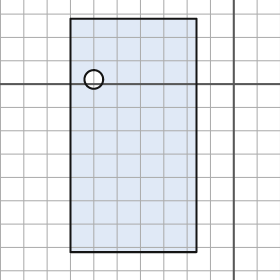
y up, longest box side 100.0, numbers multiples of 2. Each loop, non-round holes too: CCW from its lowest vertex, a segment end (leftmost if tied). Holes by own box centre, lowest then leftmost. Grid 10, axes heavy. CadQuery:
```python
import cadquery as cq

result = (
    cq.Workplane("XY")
    .moveTo(-70.0, -72.0)
    .lineTo(-16.0, -72.0)
    .lineTo(-16.0, 28.0)
    .lineTo(-70.0, 28.0)
    .close()
    .moveTo(-60.0, 2.0)
    .circle(4.0)
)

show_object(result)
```